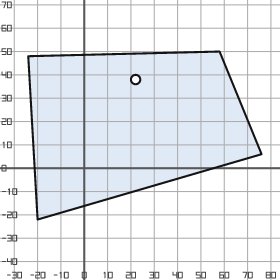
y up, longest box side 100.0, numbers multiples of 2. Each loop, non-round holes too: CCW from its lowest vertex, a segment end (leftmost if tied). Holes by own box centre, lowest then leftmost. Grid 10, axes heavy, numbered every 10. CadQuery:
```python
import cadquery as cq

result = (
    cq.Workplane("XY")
    .moveTo(-20.0, -22.0)
    .lineTo(76.0, 6.0)
    .lineTo(58.0, 50.0)
    .lineTo(-24.0, 48.0)
    .close()
    .moveTo(22.0, 38.0)
    .circle(2.0)
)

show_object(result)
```